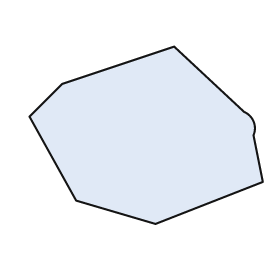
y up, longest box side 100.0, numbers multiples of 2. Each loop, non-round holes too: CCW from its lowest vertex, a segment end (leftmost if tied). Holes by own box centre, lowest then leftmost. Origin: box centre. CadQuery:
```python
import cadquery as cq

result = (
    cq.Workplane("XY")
    .moveTo(4.0, -38.0)
    .lineTo(50.0, -20.0)
    .lineTo(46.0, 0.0)
    .threePointArc((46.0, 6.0), (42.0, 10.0))
    .lineTo(12.0, 38.0)
    .lineTo(-36.0, 22.0)
    .lineTo(-50.0, 8.0)
    .lineTo(-30.0, -28.0)
    .close()
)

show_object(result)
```